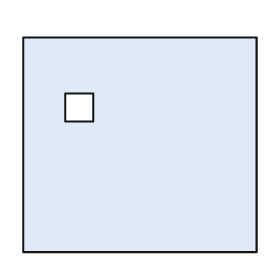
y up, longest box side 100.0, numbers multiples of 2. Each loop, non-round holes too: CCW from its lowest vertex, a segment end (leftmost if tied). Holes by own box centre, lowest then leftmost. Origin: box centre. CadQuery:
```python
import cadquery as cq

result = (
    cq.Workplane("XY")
    .moveTo(-50.0, -46.0)
    .lineTo(50.0, -46.0)
    .lineTo(50.0, 46.0)
    .lineTo(-50.0, 46.0)
    .close()
    .moveTo(-32.0, 10.0)
    .lineTo(-20.0, 10.0)
    .lineTo(-20.0, 22.0)
    .lineTo(-32.0, 22.0)
    .close()
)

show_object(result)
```